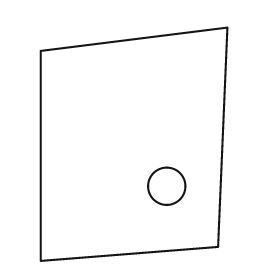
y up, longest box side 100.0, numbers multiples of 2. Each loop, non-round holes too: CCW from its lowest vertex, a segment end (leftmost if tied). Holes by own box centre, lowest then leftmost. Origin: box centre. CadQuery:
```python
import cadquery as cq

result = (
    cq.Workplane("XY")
    .moveTo(-40.0, -50.0)
    .lineTo(36.0, -44.0)
    .lineTo(40.0, 50.0)
    .lineTo(-40.0, 40.0)
    .close()
    .moveTo(14.0, -18.0)
    .circle(8.0)
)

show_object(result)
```